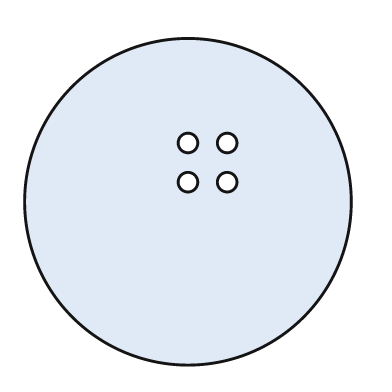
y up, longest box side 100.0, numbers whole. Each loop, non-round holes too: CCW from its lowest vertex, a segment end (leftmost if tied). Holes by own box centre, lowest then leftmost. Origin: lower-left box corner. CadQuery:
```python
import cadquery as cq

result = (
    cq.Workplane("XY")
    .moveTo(50.0, 50.0)
    .circle(50.0)
    .moveTo(50.0, 56.0)
    .circle(3.0)
    .moveTo(62.0, 56.0)
    .circle(3.0)
    .moveTo(50.0, 68.0)
    .circle(3.0)
    .moveTo(62.0, 68.0)
    .circle(3.0)
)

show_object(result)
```